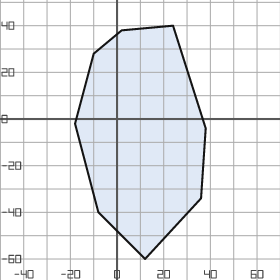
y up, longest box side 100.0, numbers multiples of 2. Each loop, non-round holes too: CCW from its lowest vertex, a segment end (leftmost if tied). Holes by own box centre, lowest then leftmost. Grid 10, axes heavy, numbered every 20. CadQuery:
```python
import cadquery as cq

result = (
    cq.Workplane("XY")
    .moveTo(12.0, -60.0)
    .lineTo(36.0, -34.0)
    .lineTo(38.0, -4.0)
    .lineTo(24.0, 40.0)
    .lineTo(2.0, 38.0)
    .lineTo(-10.0, 28.0)
    .lineTo(-18.0, -2.0)
    .lineTo(-8.0, -40.0)
    .close()
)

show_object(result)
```